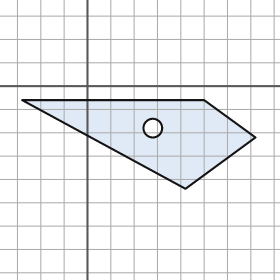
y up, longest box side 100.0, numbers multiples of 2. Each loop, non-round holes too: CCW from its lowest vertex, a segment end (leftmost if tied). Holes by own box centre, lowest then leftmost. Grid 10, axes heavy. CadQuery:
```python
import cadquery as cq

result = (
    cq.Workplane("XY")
    .moveTo(42.0, -44.0)
    .lineTo(72.0, -22.0)
    .lineTo(50.0, -6.0)
    .lineTo(-28.0, -6.0)
    .close()
    .moveTo(28.0, -18.0)
    .circle(4.0)
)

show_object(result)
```